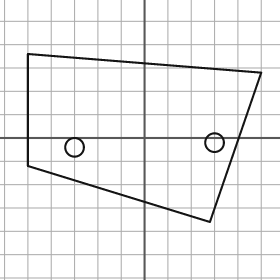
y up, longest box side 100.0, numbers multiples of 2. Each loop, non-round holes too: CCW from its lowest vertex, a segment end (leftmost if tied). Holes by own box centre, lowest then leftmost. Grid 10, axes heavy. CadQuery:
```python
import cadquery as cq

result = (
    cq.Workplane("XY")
    .moveTo(28.0, -36.0)
    .lineTo(50.0, 28.0)
    .lineTo(-50.0, 36.0)
    .lineTo(-50.0, -12.0)
    .close()
    .moveTo(-30.0, -4.0)
    .circle(4.0)
    .moveTo(30.0, -2.0)
    .circle(4.0)
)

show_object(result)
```